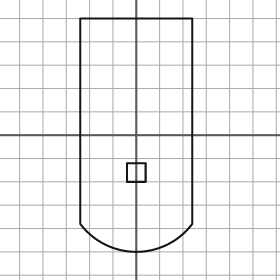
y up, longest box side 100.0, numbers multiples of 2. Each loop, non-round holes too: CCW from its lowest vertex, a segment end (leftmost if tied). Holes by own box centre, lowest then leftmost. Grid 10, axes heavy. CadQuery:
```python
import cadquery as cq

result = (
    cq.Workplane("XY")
    .moveTo(-24.0, -38.0)
    .threePointArc((0.0, -50.0), (24.0, -38.0))
    .lineTo(24.0, 50.0)
    .lineTo(-24.0, 50.0)
    .close()
    .moveTo(-4.0, -20.0)
    .lineTo(4.0, -20.0)
    .lineTo(4.0, -12.0)
    .lineTo(-4.0, -12.0)
    .close()
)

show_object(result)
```